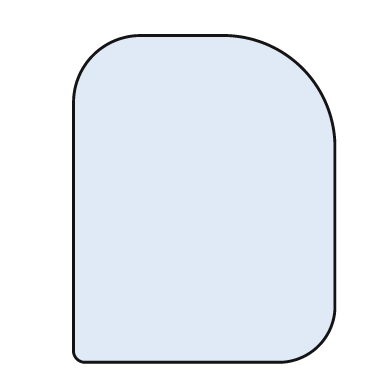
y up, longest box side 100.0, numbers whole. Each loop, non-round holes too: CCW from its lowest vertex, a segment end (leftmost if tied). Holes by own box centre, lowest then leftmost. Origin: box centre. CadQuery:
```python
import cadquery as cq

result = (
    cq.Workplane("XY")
    .moveTo(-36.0, -50.0)
    .lineTo(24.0, -50.0)
    .threePointArc((35.0, -45.0), (40.0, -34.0))
    .lineTo(40.0, 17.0)
    .threePointArc((30.0, 40.0), (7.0, 50.0))
    .lineTo(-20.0, 50.0)
    .threePointArc((-34.0, 44.0), (-40.0, 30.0))
    .lineTo(-40.0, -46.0)
    .threePointArc((-39.0, -49.0), (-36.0, -50.0))
    .close()
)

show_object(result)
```